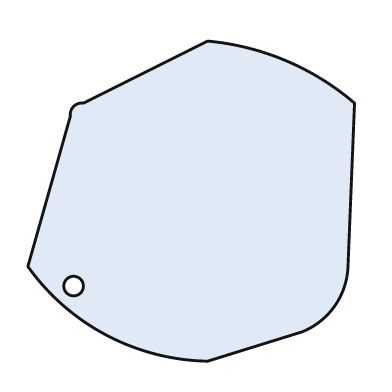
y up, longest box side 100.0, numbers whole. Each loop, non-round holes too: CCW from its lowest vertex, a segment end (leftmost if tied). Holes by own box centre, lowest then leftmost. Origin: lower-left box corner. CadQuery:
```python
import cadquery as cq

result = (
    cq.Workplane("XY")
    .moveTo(55.0, 0.0)
    .lineTo(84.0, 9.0)
    .threePointArc((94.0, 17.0), (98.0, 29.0))
    .lineTo(100.0, 79.0)
    .threePointArc((79.0, 92.0), (55.0, 98.0))
    .lineTo(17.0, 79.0)
    .threePointArc((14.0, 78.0), (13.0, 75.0))
    .lineTo(0.0, 29.0)
    .threePointArc((24.0, 8.0), (55.0, 0.0))
    .close()
    .moveTo(14.0, 23.0)
    .circle(3.0)
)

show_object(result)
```